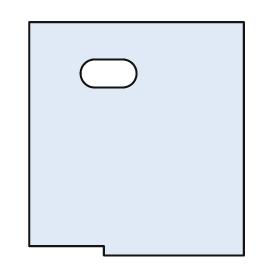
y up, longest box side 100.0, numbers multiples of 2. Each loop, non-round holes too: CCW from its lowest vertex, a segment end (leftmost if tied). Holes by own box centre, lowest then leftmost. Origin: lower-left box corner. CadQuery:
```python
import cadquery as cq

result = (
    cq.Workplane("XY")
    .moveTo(32.0, 0.0)
    .lineTo(92.0, 0.0)
    .lineTo(92.0, 100.0)
    .lineTo(0.0, 100.0)
    .lineTo(0.0, 4.0)
    .lineTo(32.0, 4.0)
    .close()
    .moveTo(28.0, 72.0)
    .lineTo(40.0, 72.0)
    .threePointArc((46.0, 78.0), (40.0, 84.0))
    .lineTo(28.0, 84.0)
    .threePointArc((22.0, 78.0), (28.0, 72.0))
    .close()
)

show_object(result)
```